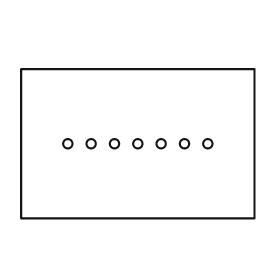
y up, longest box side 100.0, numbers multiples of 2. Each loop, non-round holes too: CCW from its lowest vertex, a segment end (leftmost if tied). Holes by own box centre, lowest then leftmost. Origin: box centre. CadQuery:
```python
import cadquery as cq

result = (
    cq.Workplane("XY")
    .moveTo(-50.0, -32.0)
    .lineTo(50.0, -32.0)
    .lineTo(50.0, 32.0)
    .lineTo(-50.0, 32.0)
    .close()
    .moveTo(-30.0, 0.0)
    .circle(2.0)
    .moveTo(-20.0, 0.0)
    .circle(2.0)
    .moveTo(-10.0, 0.0)
    .circle(2.0)
    .moveTo(0.0, 0.0)
    .circle(2.0)
    .moveTo(10.0, 0.0)
    .circle(2.0)
    .moveTo(20.0, 0.0)
    .circle(2.0)
    .moveTo(30.0, 0.0)
    .circle(2.0)
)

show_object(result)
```